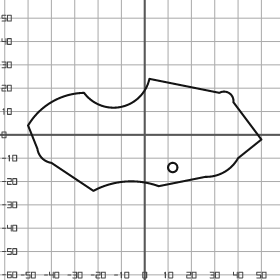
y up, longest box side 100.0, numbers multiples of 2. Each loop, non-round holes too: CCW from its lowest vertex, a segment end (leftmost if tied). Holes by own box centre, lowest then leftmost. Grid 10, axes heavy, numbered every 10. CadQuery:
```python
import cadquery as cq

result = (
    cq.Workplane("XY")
    .moveTo(-22.0, -24.0)
    .threePointArc((-8.0, -20.0), (6.0, -22.0))
    .lineTo(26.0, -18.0)
    .threePointArc((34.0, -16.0), (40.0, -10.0))
    .lineTo(50.0, -2.0)
    .lineTo(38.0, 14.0)
    .threePointArc((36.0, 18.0), (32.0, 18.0))
    .lineTo(2.0, 24.0)
    .threePointArc((-10.0, 12.0), (-26.0, 18.0))
    .threePointArc((-40.0, 14.0), (-50.0, 4.0))
    .lineTo(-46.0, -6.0)
    .threePointArc((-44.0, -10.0), (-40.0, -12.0))
    .close()
    .moveTo(12.0, -14.0)
    .circle(2.0)
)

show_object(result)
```